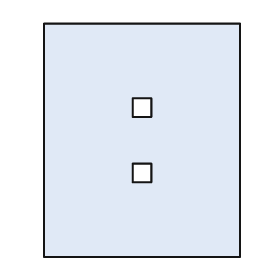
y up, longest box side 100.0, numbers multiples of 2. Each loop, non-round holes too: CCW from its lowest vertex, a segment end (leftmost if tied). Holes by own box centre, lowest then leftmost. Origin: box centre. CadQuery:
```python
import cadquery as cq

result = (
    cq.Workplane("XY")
    .moveTo(-42.0, -50.0)
    .lineTo(42.0, -50.0)
    .lineTo(42.0, 50.0)
    .lineTo(-42.0, 50.0)
    .close()
    .moveTo(-4.0, -18.0)
    .lineTo(4.0, -18.0)
    .lineTo(4.0, -10.0)
    .lineTo(-4.0, -10.0)
    .close()
    .moveTo(-4.0, 10.0)
    .lineTo(4.0, 10.0)
    .lineTo(4.0, 18.0)
    .lineTo(-4.0, 18.0)
    .close()
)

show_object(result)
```